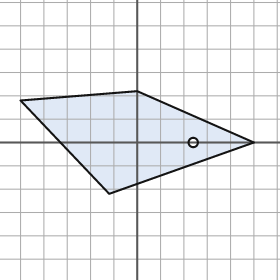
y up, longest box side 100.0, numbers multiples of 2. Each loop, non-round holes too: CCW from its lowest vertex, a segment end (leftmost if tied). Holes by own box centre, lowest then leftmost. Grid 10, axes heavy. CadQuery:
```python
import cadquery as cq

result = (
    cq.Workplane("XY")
    .moveTo(-12.0, -22.0)
    .lineTo(50.0, 0.0)
    .lineTo(0.0, 22.0)
    .lineTo(-50.0, 18.0)
    .close()
    .moveTo(24.0, 0.0)
    .circle(2.0)
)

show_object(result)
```